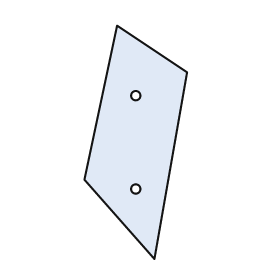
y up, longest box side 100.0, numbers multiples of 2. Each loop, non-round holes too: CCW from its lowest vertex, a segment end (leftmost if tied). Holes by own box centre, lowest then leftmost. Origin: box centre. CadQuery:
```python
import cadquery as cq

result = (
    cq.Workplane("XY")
    .moveTo(8.0, -50.0)
    .lineTo(22.0, 30.0)
    .lineTo(-8.0, 50.0)
    .lineTo(-22.0, -16.0)
    .close()
    .moveTo(0.0, -20.0)
    .circle(2.0)
    .moveTo(0.0, 20.0)
    .circle(2.0)
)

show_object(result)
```